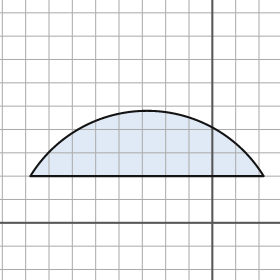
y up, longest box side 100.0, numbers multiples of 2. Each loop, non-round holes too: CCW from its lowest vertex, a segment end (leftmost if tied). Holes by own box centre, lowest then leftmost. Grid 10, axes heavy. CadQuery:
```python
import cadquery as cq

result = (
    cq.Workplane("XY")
    .moveTo(-78.0, 20.0)
    .lineTo(22.0, 20.0)
    .threePointArc((-28.0, 48.0), (-78.0, 20.0))
    .close()
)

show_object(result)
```